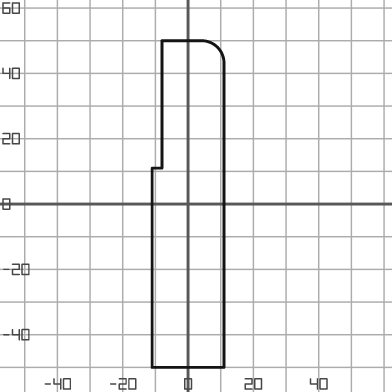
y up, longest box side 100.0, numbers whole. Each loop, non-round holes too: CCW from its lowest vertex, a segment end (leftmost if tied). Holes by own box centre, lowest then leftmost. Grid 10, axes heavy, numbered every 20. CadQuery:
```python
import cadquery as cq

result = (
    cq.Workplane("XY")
    .moveTo(-11.0, -50.0)
    .lineTo(11.0, -50.0)
    .lineTo(11.0, 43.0)
    .threePointArc((9.0, 48.0), (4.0, 50.0))
    .lineTo(-8.0, 50.0)
    .lineTo(-8.0, 11.0)
    .lineTo(-11.0, 11.0)
    .close()
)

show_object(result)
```